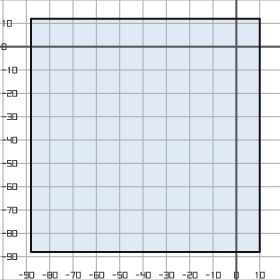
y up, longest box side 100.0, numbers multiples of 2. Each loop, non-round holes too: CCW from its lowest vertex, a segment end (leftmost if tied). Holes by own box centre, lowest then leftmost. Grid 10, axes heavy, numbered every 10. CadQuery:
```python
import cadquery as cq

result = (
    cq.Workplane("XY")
    .moveTo(-88.0, -88.0)
    .lineTo(10.0, -88.0)
    .lineTo(10.0, 12.0)
    .lineTo(-88.0, 12.0)
    .close()
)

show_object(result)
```